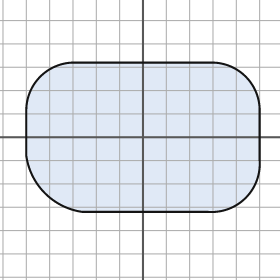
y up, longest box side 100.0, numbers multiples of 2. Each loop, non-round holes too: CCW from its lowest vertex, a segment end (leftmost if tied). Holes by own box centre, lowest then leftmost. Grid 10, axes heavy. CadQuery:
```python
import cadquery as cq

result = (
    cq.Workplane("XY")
    .moveTo(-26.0, -32.0)
    .lineTo(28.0, -32.0)
    .threePointArc((44.0, -26.0), (50.0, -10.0))
    .lineTo(50.0, 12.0)
    .threePointArc((44.0, 26.0), (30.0, 32.0))
    .lineTo(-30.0, 32.0)
    .threePointArc((-44.0, 26.0), (-50.0, 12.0))
    .lineTo(-50.0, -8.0)
    .threePointArc((-42.0, -24.0), (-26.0, -32.0))
    .close()
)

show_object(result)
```